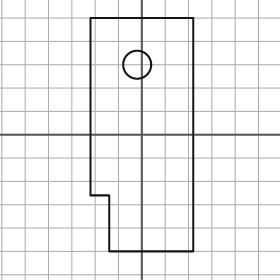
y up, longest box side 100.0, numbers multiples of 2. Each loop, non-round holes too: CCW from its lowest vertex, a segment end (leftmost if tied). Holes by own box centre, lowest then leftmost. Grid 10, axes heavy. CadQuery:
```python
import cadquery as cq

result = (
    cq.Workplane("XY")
    .moveTo(-14.0, -50.0)
    .lineTo(22.0, -50.0)
    .lineTo(22.0, 50.0)
    .lineTo(-22.0, 50.0)
    .lineTo(-22.0, -26.0)
    .lineTo(-14.0, -26.0)
    .close()
    .moveTo(-2.0, 30.0)
    .circle(6.0)
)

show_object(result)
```